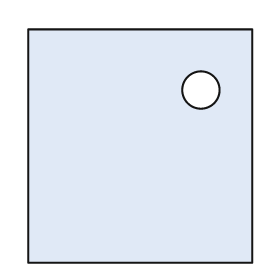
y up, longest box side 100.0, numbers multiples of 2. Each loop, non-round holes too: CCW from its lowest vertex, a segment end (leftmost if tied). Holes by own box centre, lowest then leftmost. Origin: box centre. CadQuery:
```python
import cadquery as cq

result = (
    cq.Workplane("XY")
    .moveTo(-48.0, -50.0)
    .lineTo(48.0, -50.0)
    .lineTo(48.0, 50.0)
    .lineTo(-48.0, 50.0)
    .close()
    .moveTo(26.0, 24.0)
    .circle(8.0)
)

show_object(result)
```